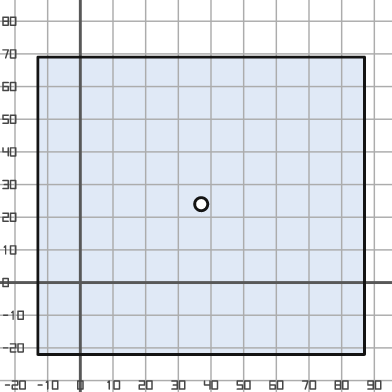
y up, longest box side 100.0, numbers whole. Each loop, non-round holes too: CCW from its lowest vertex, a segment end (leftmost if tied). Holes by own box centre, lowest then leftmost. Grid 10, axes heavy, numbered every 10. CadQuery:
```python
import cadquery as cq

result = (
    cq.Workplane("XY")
    .moveTo(-13.0, -22.0)
    .lineTo(87.0, -22.0)
    .lineTo(87.0, 69.0)
    .lineTo(-13.0, 69.0)
    .close()
    .moveTo(37.0, 24.0)
    .circle(2.0)
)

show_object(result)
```